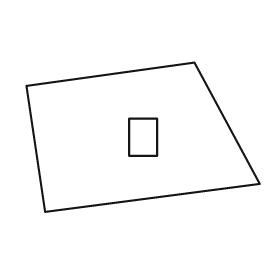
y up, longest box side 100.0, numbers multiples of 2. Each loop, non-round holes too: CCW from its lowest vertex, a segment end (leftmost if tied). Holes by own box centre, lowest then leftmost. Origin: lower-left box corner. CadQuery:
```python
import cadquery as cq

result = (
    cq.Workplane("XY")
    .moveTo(8.0, 0.0)
    .lineTo(100.0, 12.0)
    .lineTo(72.0, 64.0)
    .lineTo(0.0, 54.0)
    .close()
    .moveTo(44.0, 24.0)
    .lineTo(56.0, 24.0)
    .lineTo(56.0, 40.0)
    .lineTo(44.0, 40.0)
    .close()
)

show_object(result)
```